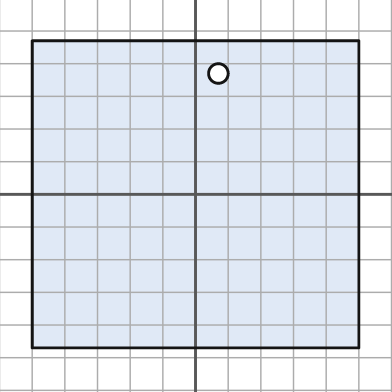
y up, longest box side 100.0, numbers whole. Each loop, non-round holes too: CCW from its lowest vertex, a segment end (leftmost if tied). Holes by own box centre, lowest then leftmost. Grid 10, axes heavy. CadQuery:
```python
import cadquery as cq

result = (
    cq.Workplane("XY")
    .moveTo(-50.0, -47.0)
    .lineTo(50.0, -47.0)
    .lineTo(50.0, 47.0)
    .lineTo(-50.0, 47.0)
    .close()
    .moveTo(7.0, 37.0)
    .circle(3.0)
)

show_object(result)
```